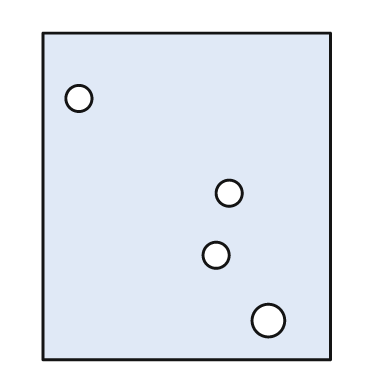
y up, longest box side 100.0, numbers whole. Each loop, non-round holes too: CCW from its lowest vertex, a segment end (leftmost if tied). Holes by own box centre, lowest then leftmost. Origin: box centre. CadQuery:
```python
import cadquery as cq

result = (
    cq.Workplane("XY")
    .moveTo(-44.0, -50.0)
    .lineTo(44.0, -50.0)
    .lineTo(44.0, 50.0)
    .lineTo(-44.0, 50.0)
    .close()
    .moveTo(25.0, -38.0)
    .circle(5.0)
    .moveTo(9.0, -18.0)
    .circle(4.0)
    .moveTo(13.0, 1.0)
    .circle(4.0)
    .moveTo(-33.0, 30.0)
    .circle(4.0)
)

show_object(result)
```